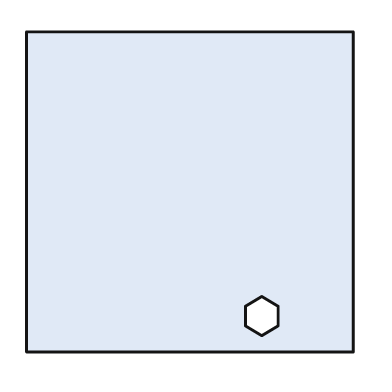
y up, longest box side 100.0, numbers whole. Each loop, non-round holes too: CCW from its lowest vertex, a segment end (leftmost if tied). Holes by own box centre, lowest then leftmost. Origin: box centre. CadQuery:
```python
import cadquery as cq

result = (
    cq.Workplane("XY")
    .moveTo(-50.0, -49.0)
    .lineTo(50.0, -49.0)
    .lineTo(50.0, 49.0)
    .lineTo(-50.0, 49.0)
    .close()
    .moveTo(22.0, -44.0)
    .lineTo(27.0, -41.0)
    .lineTo(27.0, -35.0)
    .lineTo(22.0, -32.0)
    .lineTo(17.0, -35.0)
    .lineTo(17.0, -41.0)
    .close()
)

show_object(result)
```